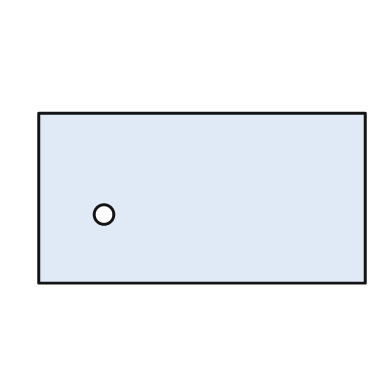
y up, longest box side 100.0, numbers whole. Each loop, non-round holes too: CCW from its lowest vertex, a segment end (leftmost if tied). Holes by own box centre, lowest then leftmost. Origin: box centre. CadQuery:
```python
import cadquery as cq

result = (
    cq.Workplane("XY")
    .moveTo(-50.0, -26.0)
    .lineTo(50.0, -26.0)
    .lineTo(50.0, 26.0)
    .lineTo(-50.0, 26.0)
    .close()
    .moveTo(-30.0, -5.0)
    .circle(3.0)
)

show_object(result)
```